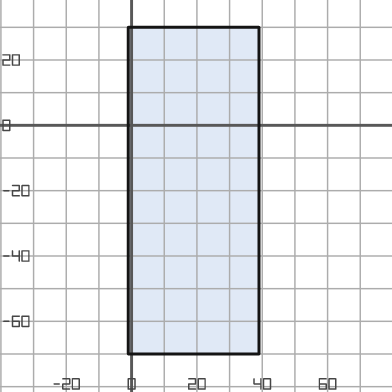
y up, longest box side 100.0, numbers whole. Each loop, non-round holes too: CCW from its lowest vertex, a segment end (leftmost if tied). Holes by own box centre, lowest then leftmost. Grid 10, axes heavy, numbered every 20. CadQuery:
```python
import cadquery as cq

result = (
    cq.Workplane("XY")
    .moveTo(-1.0, -70.0)
    .lineTo(39.0, -70.0)
    .lineTo(39.0, 30.0)
    .lineTo(-1.0, 30.0)
    .close()
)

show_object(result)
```